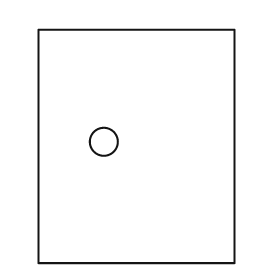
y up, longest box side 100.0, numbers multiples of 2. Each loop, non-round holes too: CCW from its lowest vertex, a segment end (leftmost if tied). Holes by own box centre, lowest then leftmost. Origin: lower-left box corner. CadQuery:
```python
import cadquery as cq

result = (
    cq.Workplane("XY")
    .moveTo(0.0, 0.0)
    .lineTo(84.0, 0.0)
    .lineTo(84.0, 100.0)
    .lineTo(0.0, 100.0)
    .close()
    .moveTo(28.0, 52.0)
    .circle(6.0)
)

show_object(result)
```